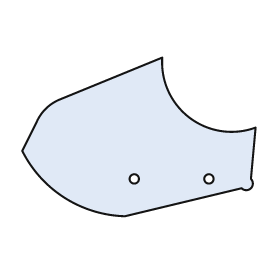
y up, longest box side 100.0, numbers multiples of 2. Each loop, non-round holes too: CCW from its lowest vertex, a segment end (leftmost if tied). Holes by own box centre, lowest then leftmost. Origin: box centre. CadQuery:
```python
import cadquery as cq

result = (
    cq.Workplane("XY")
    .moveTo(-6.0, -34.0)
    .lineTo(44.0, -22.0)
    .threePointArc((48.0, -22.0), (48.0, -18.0))
    .lineTo(50.0, 4.0)
    .threePointArc((22.0, 8.0), (10.0, 34.0))
    .lineTo(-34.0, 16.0)
    .threePointArc((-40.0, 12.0), (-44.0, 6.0))
    .lineTo(-50.0, -6.0)
    .threePointArc((-32.0, -26.0), (-6.0, -34.0))
    .close()
    .moveTo(-2.0, -18.0)
    .circle(2.0)
    .moveTo(30.0, -18.0)
    .circle(2.0)
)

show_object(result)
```